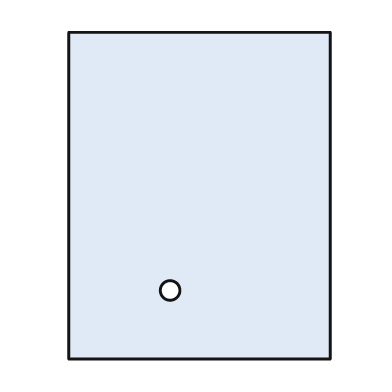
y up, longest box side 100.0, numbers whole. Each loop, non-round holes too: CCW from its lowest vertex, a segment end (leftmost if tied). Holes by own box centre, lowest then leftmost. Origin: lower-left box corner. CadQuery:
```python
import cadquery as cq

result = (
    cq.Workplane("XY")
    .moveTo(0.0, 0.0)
    .lineTo(80.0, 0.0)
    .lineTo(80.0, 100.0)
    .lineTo(0.0, 100.0)
    .close()
    .moveTo(31.0, 21.0)
    .circle(3.0)
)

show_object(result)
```